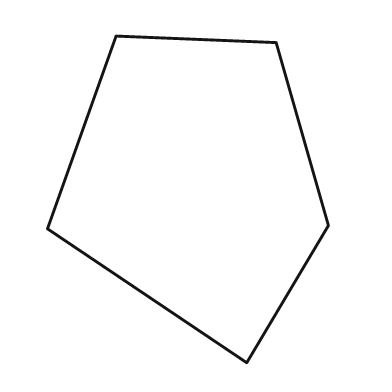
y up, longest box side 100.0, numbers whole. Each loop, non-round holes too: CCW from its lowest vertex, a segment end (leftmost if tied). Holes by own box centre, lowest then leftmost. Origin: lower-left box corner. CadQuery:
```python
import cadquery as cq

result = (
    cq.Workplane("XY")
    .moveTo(61.0, 0.0)
    .lineTo(86.0, 42.0)
    .lineTo(70.0, 98.0)
    .lineTo(21.0, 100.0)
    .lineTo(0.0, 41.0)
    .close()
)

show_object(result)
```